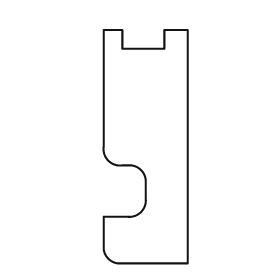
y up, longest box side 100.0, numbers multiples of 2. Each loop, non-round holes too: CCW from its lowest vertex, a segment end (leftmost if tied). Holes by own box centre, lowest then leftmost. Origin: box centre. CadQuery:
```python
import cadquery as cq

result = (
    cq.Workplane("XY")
    .moveTo(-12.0, -50.0)
    .lineTo(18.0, -50.0)
    .lineTo(18.0, 50.0)
    .lineTo(8.0, 50.0)
    .lineTo(8.0, 42.0)
    .lineTo(-10.0, 42.0)
    .lineTo(-10.0, 50.0)
    .lineTo(-18.0, 50.0)
    .lineTo(-18.0, 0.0)
    .threePointArc((-16.0, -6.0), (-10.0, -8.0))
    .lineTo(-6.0, -8.0)
    .threePointArc((-2.0, -10.0), (0.0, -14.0))
    .lineTo(0.0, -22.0)
    .threePointArc((-2.0, -28.0), (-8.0, -30.0))
    .lineTo(-18.0, -30.0)
    .lineTo(-18.0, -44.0)
    .threePointArc((-16.0, -48.0), (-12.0, -50.0))
    .close()
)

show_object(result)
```